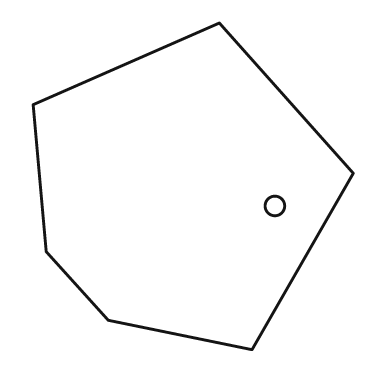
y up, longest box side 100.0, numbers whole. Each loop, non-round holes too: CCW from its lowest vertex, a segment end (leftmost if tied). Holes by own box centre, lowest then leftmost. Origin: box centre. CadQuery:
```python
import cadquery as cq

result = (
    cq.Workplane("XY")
    .moveTo(18.0, -50.0)
    .lineTo(49.0, 4.0)
    .lineTo(8.0, 50.0)
    .lineTo(-49.0, 25.0)
    .lineTo(-45.0, -20.0)
    .lineTo(-26.0, -41.0)
    .close()
    .moveTo(25.0, -6.0)
    .circle(3.0)
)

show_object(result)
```